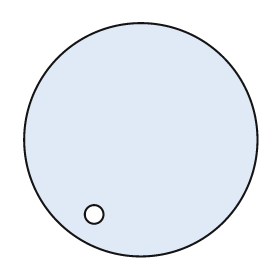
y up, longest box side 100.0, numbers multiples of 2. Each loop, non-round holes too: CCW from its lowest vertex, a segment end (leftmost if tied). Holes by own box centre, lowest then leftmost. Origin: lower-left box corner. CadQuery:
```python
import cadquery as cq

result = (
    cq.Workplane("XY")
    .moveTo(50.0, 50.0)
    .circle(50.0)
    .moveTo(30.0, 18.0)
    .circle(4.0)
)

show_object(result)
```